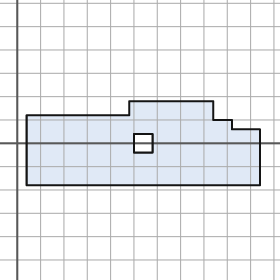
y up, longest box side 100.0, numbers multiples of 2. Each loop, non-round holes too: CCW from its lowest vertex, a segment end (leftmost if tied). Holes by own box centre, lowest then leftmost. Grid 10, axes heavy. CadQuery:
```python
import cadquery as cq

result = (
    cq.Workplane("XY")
    .moveTo(4.0, -18.0)
    .lineTo(104.0, -18.0)
    .lineTo(104.0, 6.0)
    .lineTo(92.0, 6.0)
    .lineTo(92.0, 10.0)
    .lineTo(84.0, 10.0)
    .lineTo(84.0, 18.0)
    .lineTo(48.0, 18.0)
    .lineTo(48.0, 12.0)
    .lineTo(4.0, 12.0)
    .close()
    .moveTo(50.0, -4.0)
    .lineTo(58.0, -4.0)
    .lineTo(58.0, 4.0)
    .lineTo(50.0, 4.0)
    .close()
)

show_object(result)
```